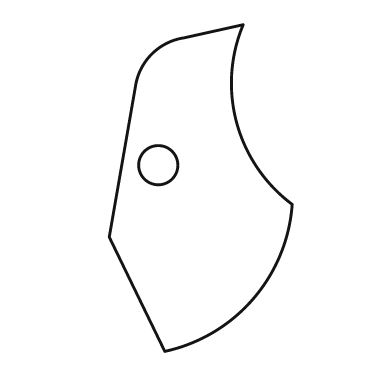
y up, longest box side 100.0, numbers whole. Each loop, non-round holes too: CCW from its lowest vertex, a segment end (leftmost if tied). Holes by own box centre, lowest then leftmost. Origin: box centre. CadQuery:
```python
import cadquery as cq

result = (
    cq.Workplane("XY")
    .moveTo(-11.0, -50.0)
    .threePointArc((16.0, -34.0), (28.0, -5.0))
    .threePointArc((11.0, 20.0), (13.0, 50.0))
    .lineTo(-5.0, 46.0)
    .threePointArc((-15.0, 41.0), (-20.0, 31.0))
    .lineTo(-28.0, -15.0)
    .close()
    .moveTo(-13.0, 7.0)
    .circle(6.0)
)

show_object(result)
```